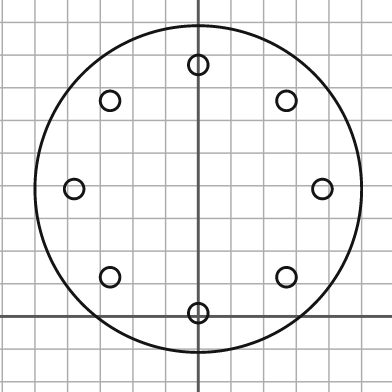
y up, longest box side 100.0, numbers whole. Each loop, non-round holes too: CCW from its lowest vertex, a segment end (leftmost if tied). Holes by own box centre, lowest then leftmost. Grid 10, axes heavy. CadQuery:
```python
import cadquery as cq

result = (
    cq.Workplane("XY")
    .moveTo(0.0, 39.0)
    .circle(50.0)
    .moveTo(0.0, 1.0)
    .circle(3.0)
    .moveTo(-27.0, 12.0)
    .circle(3.0)
    .moveTo(27.0, 12.0)
    .circle(3.0)
    .moveTo(-38.0, 39.0)
    .circle(3.0)
    .moveTo(38.0, 39.0)
    .circle(3.0)
    .moveTo(-27.0, 66.0)
    .circle(3.0)
    .moveTo(27.0, 66.0)
    .circle(3.0)
    .moveTo(0.0, 77.0)
    .circle(3.0)
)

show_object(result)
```